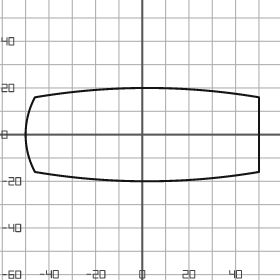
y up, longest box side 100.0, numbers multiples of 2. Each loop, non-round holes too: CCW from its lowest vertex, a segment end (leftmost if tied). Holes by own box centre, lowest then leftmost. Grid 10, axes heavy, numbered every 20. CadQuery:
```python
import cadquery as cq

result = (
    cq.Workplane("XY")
    .moveTo(-46.0, -16.0)
    .threePointArc((2.0, -20.0), (50.0, -16.0))
    .lineTo(50.0, 16.0)
    .threePointArc((2.0, 20.0), (-46.0, 16.0))
    .threePointArc((-50.0, 0.0), (-46.0, -16.0))
    .close()
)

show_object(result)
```